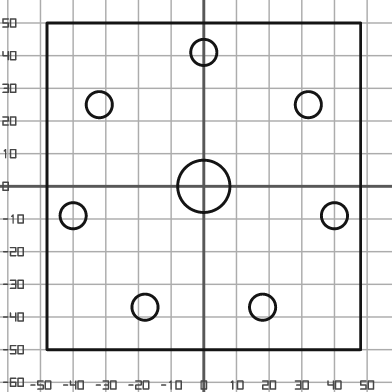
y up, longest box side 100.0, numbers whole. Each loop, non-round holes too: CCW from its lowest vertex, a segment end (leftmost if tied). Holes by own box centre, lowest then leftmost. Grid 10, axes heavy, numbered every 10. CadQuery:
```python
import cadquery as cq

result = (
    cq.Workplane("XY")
    .moveTo(-48.0, -50.0)
    .lineTo(48.0, -50.0)
    .lineTo(48.0, 50.0)
    .lineTo(-48.0, 50.0)
    .close()
    .moveTo(-18.0, -37.0)
    .circle(4.0)
    .moveTo(18.0, -37.0)
    .circle(4.0)
    .moveTo(-40.0, -9.0)
    .circle(4.0)
    .moveTo(40.0, -9.0)
    .circle(4.0)
    .moveTo(0.0, 0.0)
    .circle(8.0)
    .moveTo(-32.0, 25.0)
    .circle(4.0)
    .moveTo(32.0, 25.0)
    .circle(4.0)
    .moveTo(0.0, 41.0)
    .circle(4.0)
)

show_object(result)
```